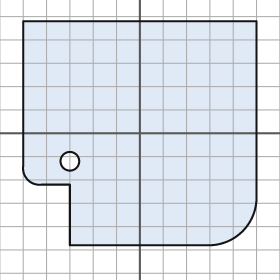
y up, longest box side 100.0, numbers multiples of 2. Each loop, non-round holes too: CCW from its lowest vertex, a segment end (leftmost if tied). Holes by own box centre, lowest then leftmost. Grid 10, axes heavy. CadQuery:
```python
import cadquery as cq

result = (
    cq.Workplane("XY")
    .moveTo(-30.0, -48.0)
    .lineTo(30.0, -48.0)
    .threePointArc((44.0, -42.0), (50.0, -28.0))
    .lineTo(50.0, 48.0)
    .lineTo(-50.0, 48.0)
    .lineTo(-50.0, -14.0)
    .threePointArc((-48.0, -20.0), (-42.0, -22.0))
    .lineTo(-30.0, -22.0)
    .close()
    .moveTo(-30.0, -12.0)
    .circle(4.0)
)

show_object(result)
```